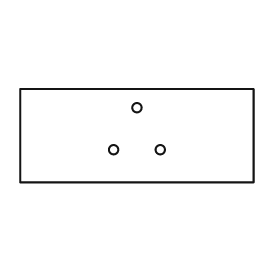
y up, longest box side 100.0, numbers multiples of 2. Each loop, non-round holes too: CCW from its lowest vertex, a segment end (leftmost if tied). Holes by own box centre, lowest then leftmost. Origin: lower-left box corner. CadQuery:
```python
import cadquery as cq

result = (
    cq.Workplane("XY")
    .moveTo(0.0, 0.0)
    .lineTo(100.0, 0.0)
    .lineTo(100.0, 40.0)
    .lineTo(0.0, 40.0)
    .close()
    .moveTo(40.0, 14.0)
    .circle(2.0)
    .moveTo(60.0, 14.0)
    .circle(2.0)
    .moveTo(50.0, 32.0)
    .circle(2.0)
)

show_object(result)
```